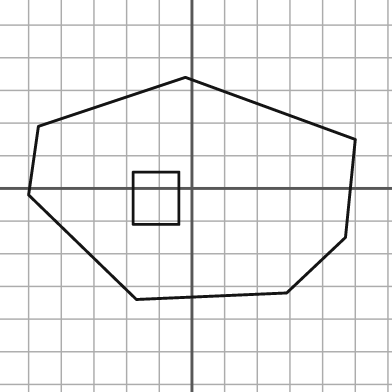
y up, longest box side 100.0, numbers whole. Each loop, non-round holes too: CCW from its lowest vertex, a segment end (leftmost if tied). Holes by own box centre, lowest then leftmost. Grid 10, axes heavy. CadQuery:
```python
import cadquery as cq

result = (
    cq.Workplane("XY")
    .moveTo(-17.0, -34.0)
    .lineTo(29.0, -32.0)
    .lineTo(47.0, -15.0)
    .lineTo(50.0, 15.0)
    .lineTo(-2.0, 34.0)
    .lineTo(-47.0, 19.0)
    .lineTo(-50.0, -2.0)
    .close()
    .moveTo(-18.0, -11.0)
    .lineTo(-4.0, -11.0)
    .lineTo(-4.0, 5.0)
    .lineTo(-18.0, 5.0)
    .close()
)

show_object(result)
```